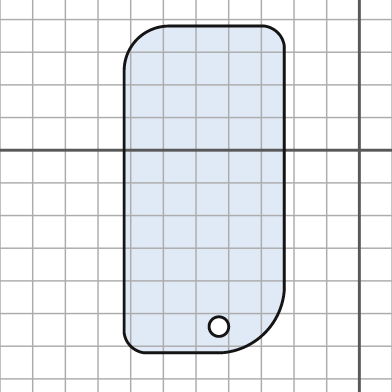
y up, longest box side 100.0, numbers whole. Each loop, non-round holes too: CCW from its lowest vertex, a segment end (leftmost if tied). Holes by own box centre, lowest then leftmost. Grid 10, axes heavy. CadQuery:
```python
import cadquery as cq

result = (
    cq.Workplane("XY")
    .moveTo(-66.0, -62.0)
    .lineTo(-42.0, -62.0)
    .threePointArc((-29.0, -56.0), (-23.0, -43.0))
    .lineTo(-23.0, 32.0)
    .threePointArc((-25.0, 36.0), (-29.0, 38.0))
    .lineTo(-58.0, 38.0)
    .threePointArc((-68.0, 34.0), (-72.0, 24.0))
    .lineTo(-72.0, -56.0)
    .threePointArc((-70.0, -60.0), (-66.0, -62.0))
    .close()
    .moveTo(-43.0, -54.0)
    .circle(3.0)
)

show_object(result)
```